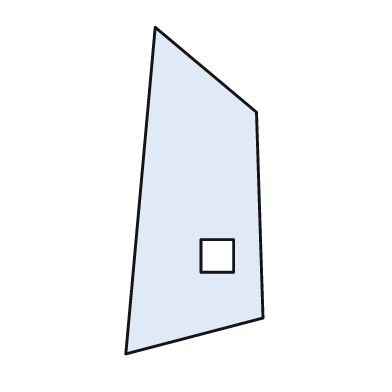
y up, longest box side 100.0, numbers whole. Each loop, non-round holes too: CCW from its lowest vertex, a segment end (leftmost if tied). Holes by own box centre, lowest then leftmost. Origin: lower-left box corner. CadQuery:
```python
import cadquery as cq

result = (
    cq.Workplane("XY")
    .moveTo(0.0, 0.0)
    .lineTo(42.0, 11.0)
    .lineTo(40.0, 74.0)
    .lineTo(9.0, 100.0)
    .close()
    .moveTo(23.0, 25.0)
    .lineTo(33.0, 25.0)
    .lineTo(33.0, 35.0)
    .lineTo(23.0, 35.0)
    .close()
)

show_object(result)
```